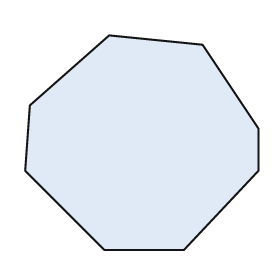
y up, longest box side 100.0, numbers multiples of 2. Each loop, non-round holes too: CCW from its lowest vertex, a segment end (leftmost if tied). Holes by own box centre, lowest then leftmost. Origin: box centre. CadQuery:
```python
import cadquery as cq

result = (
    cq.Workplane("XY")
    .moveTo(-16.0, -46.0)
    .lineTo(18.0, -46.0)
    .lineTo(50.0, -12.0)
    .lineTo(50.0, 6.0)
    .lineTo(26.0, 42.0)
    .lineTo(-14.0, 46.0)
    .lineTo(-48.0, 16.0)
    .lineTo(-50.0, -12.0)
    .close()
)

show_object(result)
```